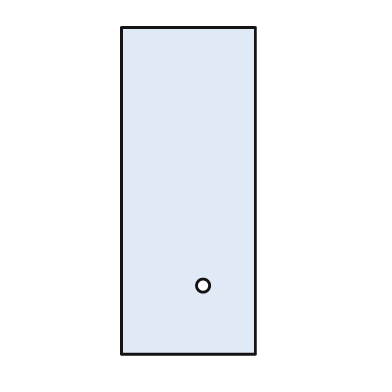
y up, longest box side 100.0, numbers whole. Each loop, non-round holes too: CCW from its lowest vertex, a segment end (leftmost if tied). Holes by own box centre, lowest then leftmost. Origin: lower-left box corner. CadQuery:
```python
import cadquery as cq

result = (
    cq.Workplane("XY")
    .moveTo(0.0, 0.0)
    .lineTo(41.0, 0.0)
    .lineTo(41.0, 100.0)
    .lineTo(0.0, 100.0)
    .close()
    .moveTo(25.0, 21.0)
    .circle(2.0)
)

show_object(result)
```